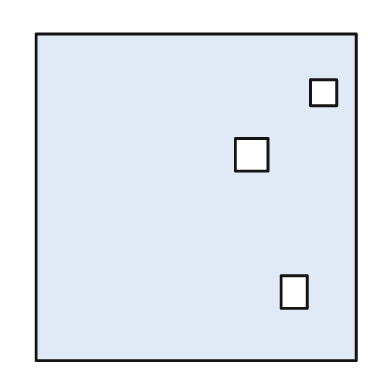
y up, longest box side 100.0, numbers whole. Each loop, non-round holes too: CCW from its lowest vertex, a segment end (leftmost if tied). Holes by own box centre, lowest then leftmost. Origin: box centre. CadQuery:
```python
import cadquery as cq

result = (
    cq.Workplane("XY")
    .moveTo(-49.0, -50.0)
    .lineTo(49.0, -50.0)
    .lineTo(49.0, 50.0)
    .lineTo(-49.0, 50.0)
    .close()
    .moveTo(26.0, -34.0)
    .lineTo(34.0, -34.0)
    .lineTo(34.0, -24.0)
    .lineTo(26.0, -24.0)
    .close()
    .moveTo(12.0, 8.0)
    .lineTo(22.0, 8.0)
    .lineTo(22.0, 18.0)
    .lineTo(12.0, 18.0)
    .close()
    .moveTo(35.0, 28.0)
    .lineTo(43.0, 28.0)
    .lineTo(43.0, 36.0)
    .lineTo(35.0, 36.0)
    .close()
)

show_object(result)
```